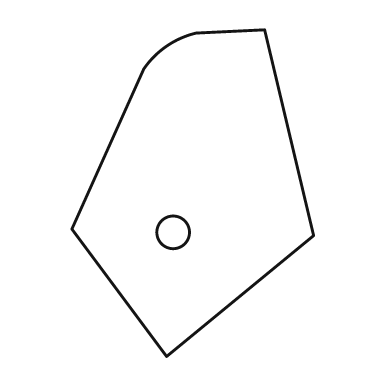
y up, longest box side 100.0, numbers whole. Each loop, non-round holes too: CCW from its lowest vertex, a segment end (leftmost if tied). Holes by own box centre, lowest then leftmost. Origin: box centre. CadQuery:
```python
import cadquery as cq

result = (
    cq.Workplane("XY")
    .moveTo(-8.0, -50.0)
    .lineTo(37.0, -13.0)
    .lineTo(22.0, 50.0)
    .lineTo(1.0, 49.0)
    .threePointArc((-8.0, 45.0), (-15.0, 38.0))
    .lineTo(-37.0, -11.0)
    .close()
    .moveTo(-6.0, -12.0)
    .circle(5.0)
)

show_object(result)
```